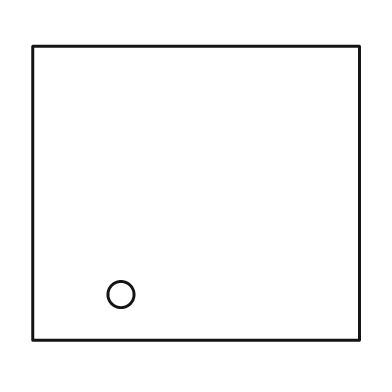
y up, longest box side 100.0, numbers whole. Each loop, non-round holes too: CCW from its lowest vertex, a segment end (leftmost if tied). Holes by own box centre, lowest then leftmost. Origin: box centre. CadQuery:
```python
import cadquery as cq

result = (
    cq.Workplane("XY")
    .moveTo(-50.0, -45.0)
    .lineTo(50.0, -45.0)
    .lineTo(50.0, 45.0)
    .lineTo(-50.0, 45.0)
    .close()
    .moveTo(-23.0, -31.0)
    .circle(4.0)
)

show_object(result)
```